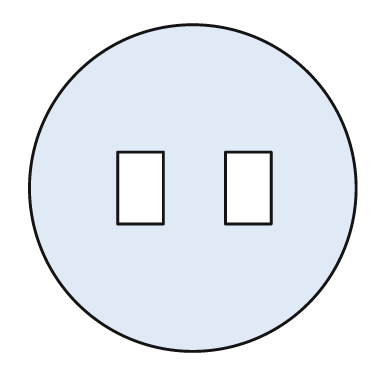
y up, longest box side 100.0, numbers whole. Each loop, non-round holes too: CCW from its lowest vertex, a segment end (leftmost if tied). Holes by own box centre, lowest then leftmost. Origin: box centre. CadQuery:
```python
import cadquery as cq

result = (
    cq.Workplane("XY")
    .moveTo(0.0, 0.0)
    .circle(50.0)
    .moveTo(-23.0, -11.0)
    .lineTo(-9.0, -11.0)
    .lineTo(-9.0, 11.0)
    .lineTo(-23.0, 11.0)
    .close()
    .moveTo(10.0, -11.0)
    .lineTo(24.0, -11.0)
    .lineTo(24.0, 11.0)
    .lineTo(10.0, 11.0)
    .close()
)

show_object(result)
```